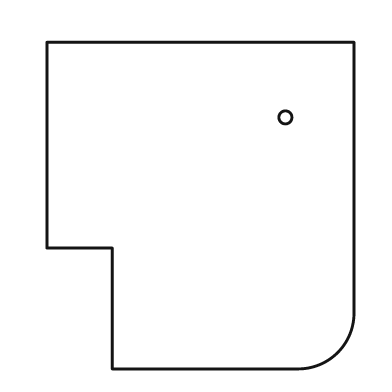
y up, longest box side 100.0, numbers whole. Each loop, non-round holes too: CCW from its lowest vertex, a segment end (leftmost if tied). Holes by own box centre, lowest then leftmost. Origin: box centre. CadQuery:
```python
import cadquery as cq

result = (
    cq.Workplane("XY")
    .moveTo(-27.0, -50.0)
    .lineTo(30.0, -50.0)
    .threePointArc((42.0, -45.0), (47.0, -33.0))
    .lineTo(47.0, 50.0)
    .lineTo(-47.0, 50.0)
    .lineTo(-47.0, -13.0)
    .lineTo(-27.0, -13.0)
    .close()
    .moveTo(26.0, 27.0)
    .circle(2.0)
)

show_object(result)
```